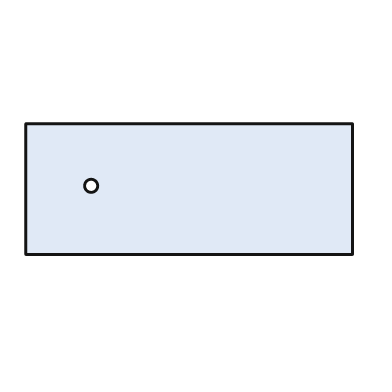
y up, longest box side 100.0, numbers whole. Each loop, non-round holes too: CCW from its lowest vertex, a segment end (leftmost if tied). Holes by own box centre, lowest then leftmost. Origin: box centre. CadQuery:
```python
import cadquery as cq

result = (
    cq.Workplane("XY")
    .moveTo(-50.0, -20.0)
    .lineTo(50.0, -20.0)
    .lineTo(50.0, 20.0)
    .lineTo(-50.0, 20.0)
    .close()
    .moveTo(-30.0, 1.0)
    .circle(2.0)
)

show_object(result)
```